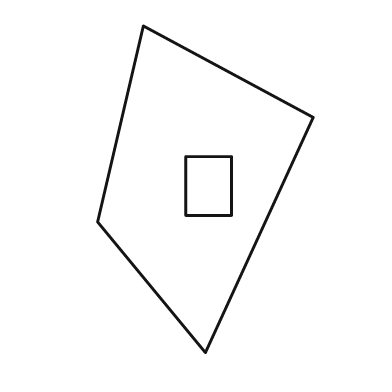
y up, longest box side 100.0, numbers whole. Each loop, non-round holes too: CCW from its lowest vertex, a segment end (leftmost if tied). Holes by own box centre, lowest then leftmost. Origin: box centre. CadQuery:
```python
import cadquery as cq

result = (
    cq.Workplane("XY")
    .moveTo(0.0, -50.0)
    .lineTo(33.0, 22.0)
    .lineTo(-19.0, 50.0)
    .lineTo(-33.0, -10.0)
    .close()
    .moveTo(-6.0, -8.0)
    .lineTo(8.0, -8.0)
    .lineTo(8.0, 10.0)
    .lineTo(-6.0, 10.0)
    .close()
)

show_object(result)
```